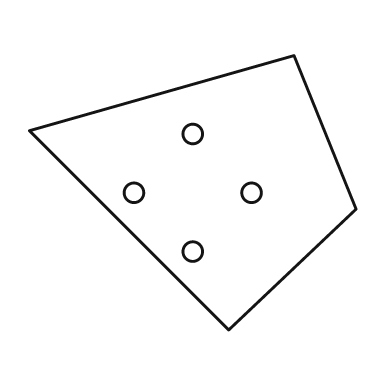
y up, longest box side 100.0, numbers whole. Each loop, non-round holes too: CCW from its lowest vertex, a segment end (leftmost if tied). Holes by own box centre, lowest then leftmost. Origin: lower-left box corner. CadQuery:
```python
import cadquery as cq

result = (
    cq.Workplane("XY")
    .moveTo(61.0, 0.0)
    .lineTo(100.0, 37.0)
    .lineTo(81.0, 84.0)
    .lineTo(0.0, 61.0)
    .close()
    .moveTo(50.0, 24.0)
    .circle(3.0)
    .moveTo(32.0, 42.0)
    .circle(3.0)
    .moveTo(68.0, 42.0)
    .circle(3.0)
    .moveTo(50.0, 60.0)
    .circle(3.0)
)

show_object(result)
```